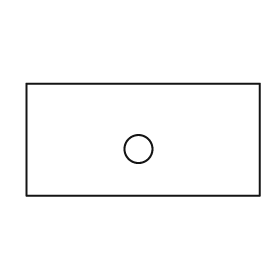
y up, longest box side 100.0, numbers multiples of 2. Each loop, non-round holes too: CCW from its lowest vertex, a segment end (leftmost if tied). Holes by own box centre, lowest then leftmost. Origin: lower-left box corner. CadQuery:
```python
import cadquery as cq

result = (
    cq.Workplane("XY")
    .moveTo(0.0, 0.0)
    .lineTo(100.0, 0.0)
    .lineTo(100.0, 48.0)
    .lineTo(0.0, 48.0)
    .close()
    .moveTo(48.0, 20.0)
    .circle(6.0)
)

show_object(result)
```